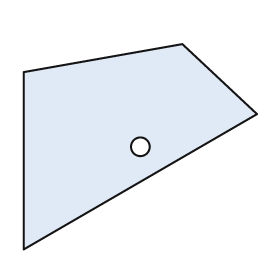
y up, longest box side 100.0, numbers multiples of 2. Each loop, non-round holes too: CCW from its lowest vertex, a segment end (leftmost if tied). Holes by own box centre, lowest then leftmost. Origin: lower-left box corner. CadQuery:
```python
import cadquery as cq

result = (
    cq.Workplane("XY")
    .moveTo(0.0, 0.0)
    .lineTo(100.0, 58.0)
    .lineTo(68.0, 88.0)
    .lineTo(0.0, 76.0)
    .close()
    .moveTo(50.0, 44.0)
    .circle(4.0)
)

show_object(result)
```